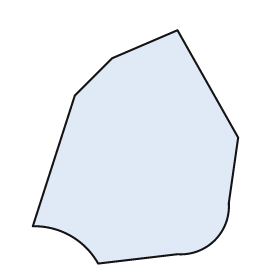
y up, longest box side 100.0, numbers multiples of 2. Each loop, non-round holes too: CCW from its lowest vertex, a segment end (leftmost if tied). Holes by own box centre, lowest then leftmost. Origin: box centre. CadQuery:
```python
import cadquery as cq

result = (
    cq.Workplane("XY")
    .moveTo(-16.0, -50.0)
    .lineTo(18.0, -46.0)
    .threePointArc((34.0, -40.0), (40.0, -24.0))
    .lineTo(44.0, 4.0)
    .lineTo(18.0, 50.0)
    .lineTo(-10.0, 38.0)
    .lineTo(-26.0, 22.0)
    .lineTo(-44.0, -34.0)
    .threePointArc((-28.0, -38.0), (-16.0, -50.0))
    .close()
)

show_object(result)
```